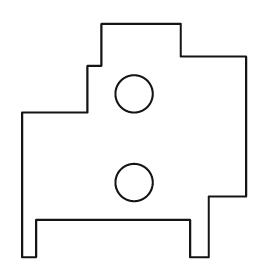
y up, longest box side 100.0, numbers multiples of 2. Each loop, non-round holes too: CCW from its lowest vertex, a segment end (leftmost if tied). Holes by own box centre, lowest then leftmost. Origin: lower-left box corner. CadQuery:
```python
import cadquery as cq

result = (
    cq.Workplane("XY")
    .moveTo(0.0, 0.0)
    .lineTo(6.0, 0.0)
    .lineTo(6.0, 16.0)
    .lineTo(72.0, 16.0)
    .lineTo(72.0, 0.0)
    .lineTo(80.0, 0.0)
    .lineTo(80.0, 26.0)
    .lineTo(96.0, 26.0)
    .lineTo(96.0, 86.0)
    .lineTo(68.0, 86.0)
    .lineTo(68.0, 100.0)
    .lineTo(34.0, 100.0)
    .lineTo(34.0, 82.0)
    .lineTo(28.0, 82.0)
    .lineTo(28.0, 62.0)
    .lineTo(0.0, 62.0)
    .close()
    .moveTo(48.0, 32.0)
    .circle(8.0)
    .moveTo(48.0, 70.0)
    .circle(8.0)
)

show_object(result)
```